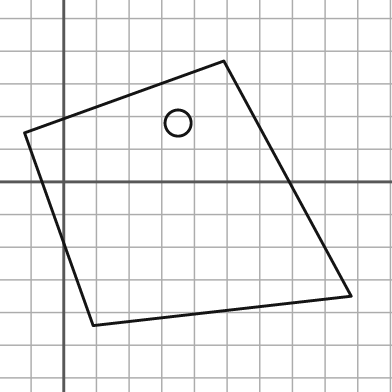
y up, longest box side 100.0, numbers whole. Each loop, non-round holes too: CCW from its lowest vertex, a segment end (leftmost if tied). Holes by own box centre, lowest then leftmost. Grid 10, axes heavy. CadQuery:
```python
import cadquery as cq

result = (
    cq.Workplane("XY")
    .moveTo(9.0, -44.0)
    .lineTo(88.0, -35.0)
    .lineTo(49.0, 37.0)
    .lineTo(-12.0, 15.0)
    .close()
    .moveTo(35.0, 18.0)
    .circle(4.0)
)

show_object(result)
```